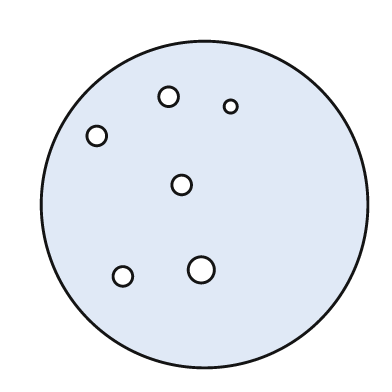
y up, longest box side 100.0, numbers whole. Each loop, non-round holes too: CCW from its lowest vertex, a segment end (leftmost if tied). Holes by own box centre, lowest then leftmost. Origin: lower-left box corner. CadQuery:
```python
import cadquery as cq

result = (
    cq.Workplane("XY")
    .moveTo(50.0, 50.0)
    .circle(50.0)
    .moveTo(25.0, 28.0)
    .circle(3.0)
    .moveTo(49.0, 30.0)
    .circle(4.0)
    .moveTo(43.0, 56.0)
    .circle(3.0)
    .moveTo(17.0, 71.0)
    .circle(3.0)
    .moveTo(58.0, 80.0)
    .circle(2.0)
    .moveTo(39.0, 83.0)
    .circle(3.0)
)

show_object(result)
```